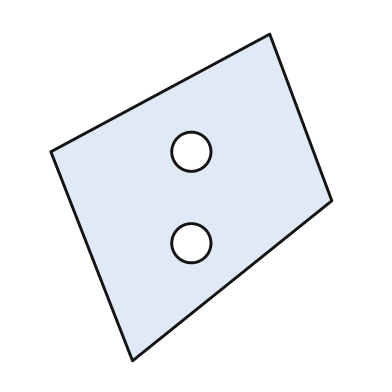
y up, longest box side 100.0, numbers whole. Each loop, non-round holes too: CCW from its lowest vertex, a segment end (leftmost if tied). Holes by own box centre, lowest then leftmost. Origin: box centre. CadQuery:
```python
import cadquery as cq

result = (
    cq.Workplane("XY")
    .moveTo(-18.0, -50.0)
    .lineTo(43.0, -1.0)
    .lineTo(24.0, 50.0)
    .lineTo(-43.0, 14.0)
    .close()
    .moveTo(0.0, -14.0)
    .circle(6.0)
    .moveTo(0.0, 14.0)
    .circle(6.0)
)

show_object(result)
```